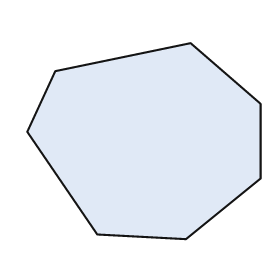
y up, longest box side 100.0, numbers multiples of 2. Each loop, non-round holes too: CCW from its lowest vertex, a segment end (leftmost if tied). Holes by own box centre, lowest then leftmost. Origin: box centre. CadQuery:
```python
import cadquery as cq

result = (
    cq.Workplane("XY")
    .moveTo(18.0, -42.0)
    .lineTo(50.0, -16.0)
    .lineTo(50.0, 16.0)
    .lineTo(20.0, 42.0)
    .lineTo(-38.0, 30.0)
    .lineTo(-50.0, 4.0)
    .lineTo(-20.0, -40.0)
    .close()
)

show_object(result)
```